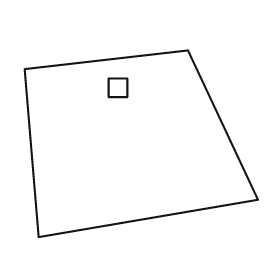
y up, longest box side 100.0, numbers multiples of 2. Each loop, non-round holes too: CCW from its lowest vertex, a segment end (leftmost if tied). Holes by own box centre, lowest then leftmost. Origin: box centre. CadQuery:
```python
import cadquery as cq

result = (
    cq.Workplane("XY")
    .moveTo(-44.0, -40.0)
    .lineTo(50.0, -24.0)
    .lineTo(20.0, 40.0)
    .lineTo(-50.0, 32.0)
    .close()
    .moveTo(-14.0, 20.0)
    .lineTo(-6.0, 20.0)
    .lineTo(-6.0, 28.0)
    .lineTo(-14.0, 28.0)
    .close()
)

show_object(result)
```